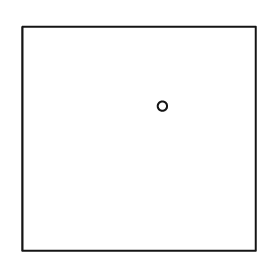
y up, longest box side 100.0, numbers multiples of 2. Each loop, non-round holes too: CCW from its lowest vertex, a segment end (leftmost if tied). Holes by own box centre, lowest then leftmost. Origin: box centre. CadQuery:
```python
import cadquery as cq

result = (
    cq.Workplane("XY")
    .moveTo(-50.0, -48.0)
    .lineTo(50.0, -48.0)
    .lineTo(50.0, 48.0)
    .lineTo(-50.0, 48.0)
    .close()
    .moveTo(10.0, 14.0)
    .circle(2.0)
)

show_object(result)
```